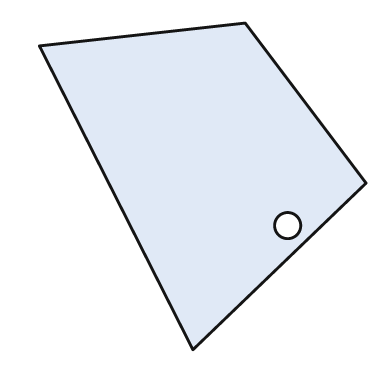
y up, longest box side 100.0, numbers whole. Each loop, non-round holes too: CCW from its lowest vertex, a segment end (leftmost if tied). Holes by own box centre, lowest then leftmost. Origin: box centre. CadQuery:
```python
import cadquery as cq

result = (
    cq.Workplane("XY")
    .moveTo(-3.0, -50.0)
    .lineTo(50.0, 1.0)
    .lineTo(13.0, 50.0)
    .lineTo(-50.0, 43.0)
    .close()
    .moveTo(26.0, -12.0)
    .circle(4.0)
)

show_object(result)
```